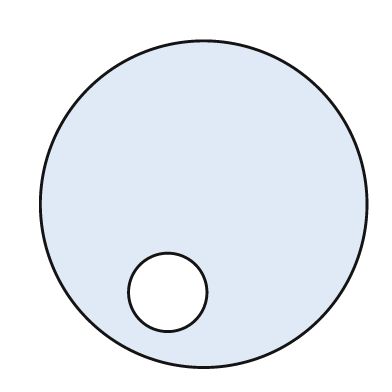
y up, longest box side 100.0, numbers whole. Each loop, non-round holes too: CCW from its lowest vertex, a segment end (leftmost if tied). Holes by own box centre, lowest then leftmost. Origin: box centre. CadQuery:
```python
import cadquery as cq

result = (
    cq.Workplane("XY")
    .moveTo(0.0, 0.0)
    .circle(50.0)
    .moveTo(-11.0, -27.0)
    .circle(12.0)
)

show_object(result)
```